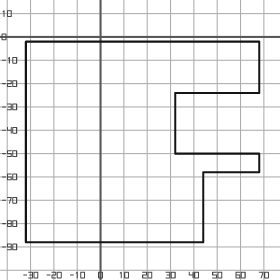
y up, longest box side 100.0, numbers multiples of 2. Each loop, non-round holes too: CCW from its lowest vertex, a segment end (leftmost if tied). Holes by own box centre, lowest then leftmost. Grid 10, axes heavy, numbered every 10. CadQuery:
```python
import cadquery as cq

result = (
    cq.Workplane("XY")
    .moveTo(-32.0, -88.0)
    .lineTo(44.0, -88.0)
    .lineTo(44.0, -58.0)
    .lineTo(68.0, -58.0)
    .lineTo(68.0, -50.0)
    .lineTo(32.0, -50.0)
    .lineTo(32.0, -24.0)
    .lineTo(68.0, -24.0)
    .lineTo(68.0, -2.0)
    .lineTo(-32.0, -2.0)
    .close()
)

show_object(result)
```